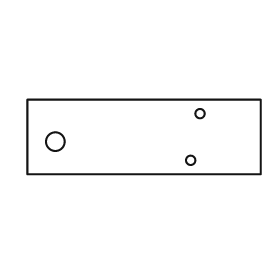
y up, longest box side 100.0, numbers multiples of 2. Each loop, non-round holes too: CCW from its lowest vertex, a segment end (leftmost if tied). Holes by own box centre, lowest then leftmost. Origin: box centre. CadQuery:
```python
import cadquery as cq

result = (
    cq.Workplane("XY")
    .moveTo(-50.0, -16.0)
    .lineTo(50.0, -16.0)
    .lineTo(50.0, 16.0)
    .lineTo(-50.0, 16.0)
    .close()
    .moveTo(20.0, -10.0)
    .circle(2.0)
    .moveTo(-38.0, -2.0)
    .circle(4.0)
    .moveTo(24.0, 10.0)
    .circle(2.0)
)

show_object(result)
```